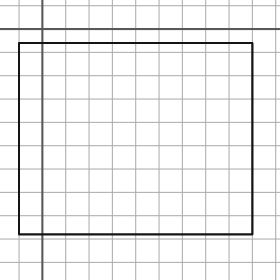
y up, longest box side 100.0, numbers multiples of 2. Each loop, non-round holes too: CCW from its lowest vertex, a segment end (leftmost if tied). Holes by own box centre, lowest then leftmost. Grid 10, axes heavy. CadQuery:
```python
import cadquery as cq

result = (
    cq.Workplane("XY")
    .moveTo(-10.0, -88.0)
    .lineTo(90.0, -88.0)
    .lineTo(90.0, -6.0)
    .lineTo(-10.0, -6.0)
    .close()
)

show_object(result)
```